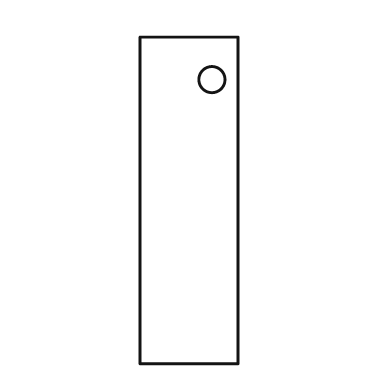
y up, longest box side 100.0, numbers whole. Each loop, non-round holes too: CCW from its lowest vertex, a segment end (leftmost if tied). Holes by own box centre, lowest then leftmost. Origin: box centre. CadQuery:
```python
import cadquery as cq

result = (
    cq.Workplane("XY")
    .moveTo(-15.0, -50.0)
    .lineTo(15.0, -50.0)
    .lineTo(15.0, 50.0)
    .lineTo(-15.0, 50.0)
    .close()
    .moveTo(7.0, 37.0)
    .circle(4.0)
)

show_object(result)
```